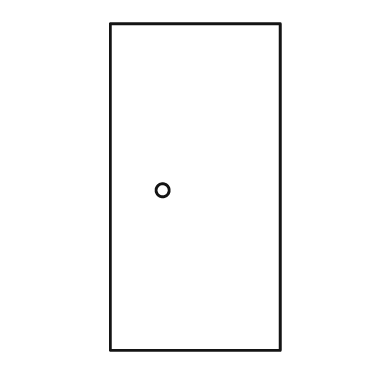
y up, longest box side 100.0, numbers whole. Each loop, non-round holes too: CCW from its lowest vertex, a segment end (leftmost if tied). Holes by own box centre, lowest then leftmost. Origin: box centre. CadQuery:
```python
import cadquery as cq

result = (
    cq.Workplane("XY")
    .moveTo(-26.0, -50.0)
    .lineTo(26.0, -50.0)
    .lineTo(26.0, 50.0)
    .lineTo(-26.0, 50.0)
    .close()
    .moveTo(-10.0, -1.0)
    .circle(2.0)
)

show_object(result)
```